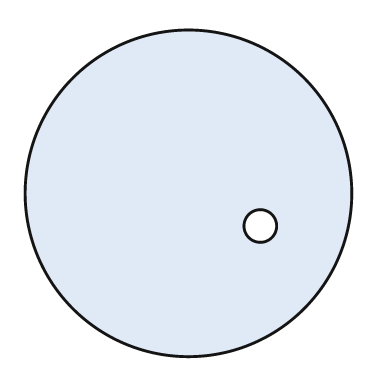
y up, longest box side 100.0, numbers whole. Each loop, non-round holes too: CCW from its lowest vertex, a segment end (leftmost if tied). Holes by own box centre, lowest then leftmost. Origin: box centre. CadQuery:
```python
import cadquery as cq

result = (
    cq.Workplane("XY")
    .moveTo(0.0, 0.0)
    .circle(50.0)
    .moveTo(22.0, -10.0)
    .circle(5.0)
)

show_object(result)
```